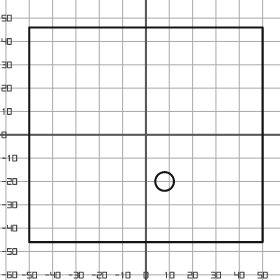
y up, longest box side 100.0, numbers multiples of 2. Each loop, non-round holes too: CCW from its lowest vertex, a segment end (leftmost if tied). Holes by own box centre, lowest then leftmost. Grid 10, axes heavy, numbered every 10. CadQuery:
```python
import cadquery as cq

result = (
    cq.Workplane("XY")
    .moveTo(-50.0, -46.0)
    .lineTo(50.0, -46.0)
    .lineTo(50.0, 46.0)
    .lineTo(-50.0, 46.0)
    .close()
    .moveTo(8.0, -20.0)
    .circle(4.0)
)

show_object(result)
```